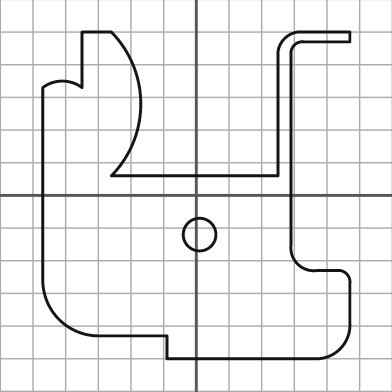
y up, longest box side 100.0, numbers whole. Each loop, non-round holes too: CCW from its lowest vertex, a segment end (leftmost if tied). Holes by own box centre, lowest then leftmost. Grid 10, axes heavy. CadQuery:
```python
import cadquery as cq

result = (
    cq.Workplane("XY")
    .moveTo(-9.0, -50.0)
    .lineTo(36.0, -50.0)
    .threePointArc((44.0, -47.0), (47.0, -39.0))
    .lineTo(47.0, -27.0)
    .threePointArc((46.0, -24.0), (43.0, -23.0))
    .lineTo(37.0, -23.0)
    .threePointArc((31.0, -21.0), (29.0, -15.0))
    .lineTo(29.0, 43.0)
    .threePointArc((30.0, 46.0), (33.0, 47.0))
    .lineTo(47.0, 47.0)
    .lineTo(47.0, 50.0)
    .lineTo(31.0, 50.0)
    .threePointArc((27.0, 48.0), (25.0, 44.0))
    .lineTo(25.0, 6.0)
    .lineTo(-26.0, 6.0)
    .threePointArc((-17.0, 28.0), (-26.0, 50.0))
    .lineTo(-35.0, 50.0)
    .lineTo(-35.0, 33.0)
    .threePointArc((-41.0, 35.0), (-47.0, 33.0))
    .lineTo(-47.0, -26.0)
    .threePointArc((-42.0, -38.0), (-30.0, -43.0))
    .lineTo(-9.0, -43.0)
    .close()
    .moveTo(1.0, -12.0)
    .circle(5.0)
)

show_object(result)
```